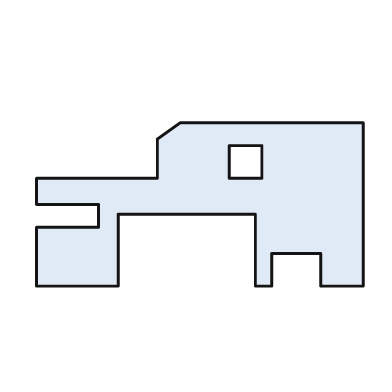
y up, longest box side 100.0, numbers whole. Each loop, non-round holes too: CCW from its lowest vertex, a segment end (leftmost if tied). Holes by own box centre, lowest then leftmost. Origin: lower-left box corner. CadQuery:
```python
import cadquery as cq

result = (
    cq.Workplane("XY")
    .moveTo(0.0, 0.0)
    .lineTo(25.0, 0.0)
    .lineTo(25.0, 22.0)
    .lineTo(67.0, 22.0)
    .lineTo(67.0, 0.0)
    .lineTo(72.0, 0.0)
    .lineTo(72.0, 10.0)
    .lineTo(87.0, 10.0)
    .lineTo(87.0, 0.0)
    .lineTo(100.0, 0.0)
    .lineTo(100.0, 50.0)
    .lineTo(44.0, 50.0)
    .lineTo(37.0, 45.0)
    .lineTo(37.0, 33.0)
    .lineTo(0.0, 33.0)
    .lineTo(0.0, 25.0)
    .lineTo(19.0, 25.0)
    .lineTo(19.0, 18.0)
    .lineTo(0.0, 18.0)
    .close()
    .moveTo(59.0, 33.0)
    .lineTo(69.0, 33.0)
    .lineTo(69.0, 43.0)
    .lineTo(59.0, 43.0)
    .close()
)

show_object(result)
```